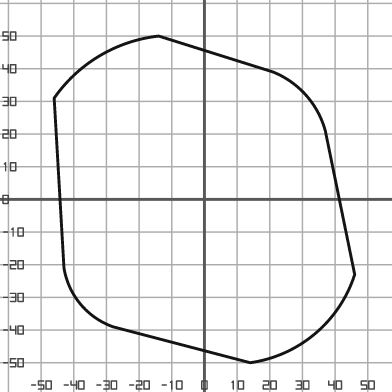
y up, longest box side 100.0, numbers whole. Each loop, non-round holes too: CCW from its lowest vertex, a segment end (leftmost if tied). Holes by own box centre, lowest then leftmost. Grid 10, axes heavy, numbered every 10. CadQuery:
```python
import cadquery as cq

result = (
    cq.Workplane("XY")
    .moveTo(14.0, -50.0)
    .threePointArc((34.0, -41.0), (46.0, -23.0))
    .lineTo(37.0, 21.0)
    .threePointArc((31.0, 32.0), (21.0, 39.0))
    .lineTo(-14.0, 50.0)
    .threePointArc((-32.0, 44.0), (-46.0, 31.0))
    .lineTo(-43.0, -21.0)
    .threePointArc((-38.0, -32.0), (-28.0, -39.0))
    .close()
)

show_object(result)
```